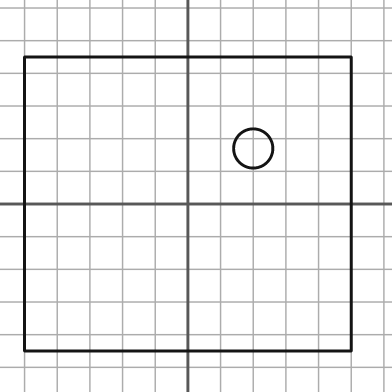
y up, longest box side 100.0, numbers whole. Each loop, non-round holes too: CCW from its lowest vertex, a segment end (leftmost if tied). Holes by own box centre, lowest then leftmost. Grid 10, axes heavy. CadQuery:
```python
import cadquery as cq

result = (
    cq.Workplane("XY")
    .moveTo(-50.0, -45.0)
    .lineTo(50.0, -45.0)
    .lineTo(50.0, 45.0)
    .lineTo(-50.0, 45.0)
    .close()
    .moveTo(20.0, 17.0)
    .circle(6.0)
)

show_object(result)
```